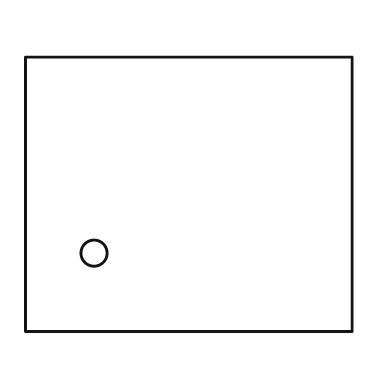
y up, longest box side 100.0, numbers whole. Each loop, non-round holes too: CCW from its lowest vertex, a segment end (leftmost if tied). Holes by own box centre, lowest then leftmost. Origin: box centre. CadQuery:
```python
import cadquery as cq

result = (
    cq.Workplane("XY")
    .moveTo(-50.0, -42.0)
    .lineTo(50.0, -42.0)
    .lineTo(50.0, 42.0)
    .lineTo(-50.0, 42.0)
    .close()
    .moveTo(-29.0, -18.0)
    .circle(4.0)
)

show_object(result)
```